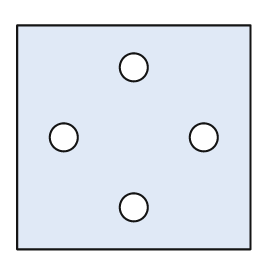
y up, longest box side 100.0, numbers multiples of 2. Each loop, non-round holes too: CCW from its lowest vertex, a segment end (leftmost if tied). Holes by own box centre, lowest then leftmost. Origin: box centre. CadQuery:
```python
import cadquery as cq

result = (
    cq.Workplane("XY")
    .moveTo(-50.0, -48.0)
    .lineTo(50.0, -48.0)
    .lineTo(50.0, 48.0)
    .lineTo(-50.0, 48.0)
    .close()
    .moveTo(0.0, -30.0)
    .circle(6.0)
    .moveTo(-30.0, 0.0)
    .circle(6.0)
    .moveTo(30.0, 0.0)
    .circle(6.0)
    .moveTo(0.0, 30.0)
    .circle(6.0)
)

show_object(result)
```